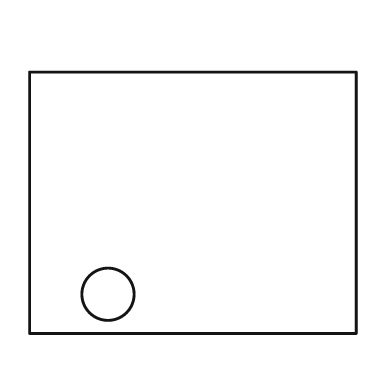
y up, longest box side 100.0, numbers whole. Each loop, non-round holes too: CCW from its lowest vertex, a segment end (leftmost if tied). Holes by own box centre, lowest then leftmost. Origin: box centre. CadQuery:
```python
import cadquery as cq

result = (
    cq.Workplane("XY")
    .moveTo(-50.0, -40.0)
    .lineTo(50.0, -40.0)
    .lineTo(50.0, 40.0)
    .lineTo(-50.0, 40.0)
    .close()
    .moveTo(-26.0, -28.0)
    .circle(8.0)
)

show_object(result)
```